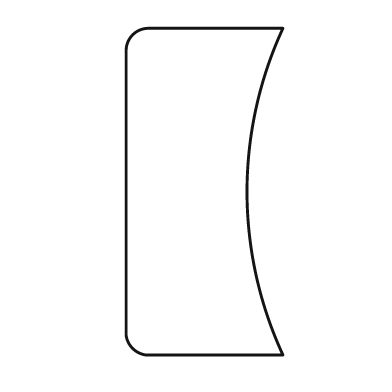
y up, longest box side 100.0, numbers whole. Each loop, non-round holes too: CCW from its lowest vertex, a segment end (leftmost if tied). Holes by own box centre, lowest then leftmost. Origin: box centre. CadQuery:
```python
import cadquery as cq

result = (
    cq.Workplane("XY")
    .moveTo(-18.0, -50.0)
    .lineTo(24.0, -50.0)
    .threePointArc((13.0, 0.0), (24.0, 50.0))
    .lineTo(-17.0, 50.0)
    .threePointArc((-22.0, 48.0), (-24.0, 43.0))
    .lineTo(-24.0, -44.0)
    .threePointArc((-22.0, -48.0), (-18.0, -50.0))
    .close()
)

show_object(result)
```